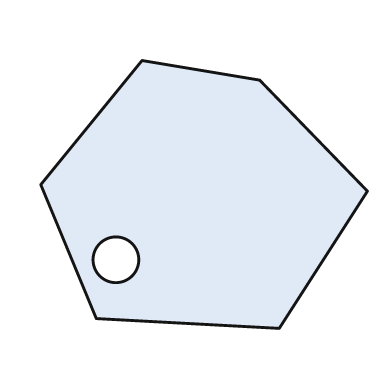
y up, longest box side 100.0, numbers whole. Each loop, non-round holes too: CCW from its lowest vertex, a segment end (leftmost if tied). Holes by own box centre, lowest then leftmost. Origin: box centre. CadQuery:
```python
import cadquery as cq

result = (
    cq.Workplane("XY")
    .moveTo(23.0, -41.0)
    .lineTo(50.0, 1.0)
    .lineTo(17.0, 35.0)
    .lineTo(-19.0, 41.0)
    .lineTo(-50.0, 3.0)
    .lineTo(-33.0, -38.0)
    .close()
    .moveTo(-27.0, -20.0)
    .circle(7.0)
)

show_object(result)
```